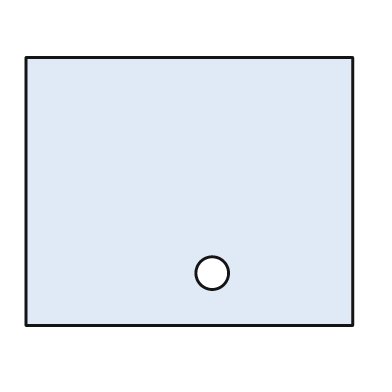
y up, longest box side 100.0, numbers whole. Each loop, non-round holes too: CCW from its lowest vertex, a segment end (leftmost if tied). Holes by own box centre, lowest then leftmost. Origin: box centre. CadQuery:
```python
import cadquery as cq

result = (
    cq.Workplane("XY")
    .moveTo(-50.0, -41.0)
    .lineTo(50.0, -41.0)
    .lineTo(50.0, 41.0)
    .lineTo(-50.0, 41.0)
    .close()
    .moveTo(7.0, -25.0)
    .circle(5.0)
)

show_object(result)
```